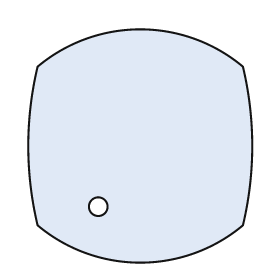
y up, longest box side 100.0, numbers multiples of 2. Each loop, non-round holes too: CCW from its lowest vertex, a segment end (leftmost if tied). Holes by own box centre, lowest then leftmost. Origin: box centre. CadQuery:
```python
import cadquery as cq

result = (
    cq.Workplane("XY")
    .moveTo(-44.0, -34.0)
    .threePointArc((0.0, -50.0), (44.0, -34.0))
    .threePointArc((48.0, 0.0), (44.0, 34.0))
    .threePointArc((0.0, 50.0), (-44.0, 34.0))
    .threePointArc((-48.0, 0.0), (-44.0, -34.0))
    .close()
    .moveTo(-18.0, -26.0)
    .circle(4.0)
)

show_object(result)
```